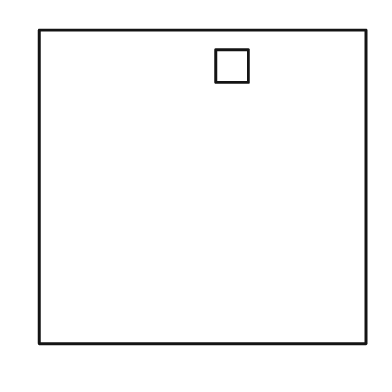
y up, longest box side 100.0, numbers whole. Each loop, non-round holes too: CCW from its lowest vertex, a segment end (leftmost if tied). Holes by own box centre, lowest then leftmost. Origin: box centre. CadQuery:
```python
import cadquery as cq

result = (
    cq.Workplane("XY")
    .moveTo(-50.0, -48.0)
    .lineTo(50.0, -48.0)
    .lineTo(50.0, 48.0)
    .lineTo(-50.0, 48.0)
    .close()
    .moveTo(4.0, 32.0)
    .lineTo(14.0, 32.0)
    .lineTo(14.0, 42.0)
    .lineTo(4.0, 42.0)
    .close()
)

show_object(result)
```